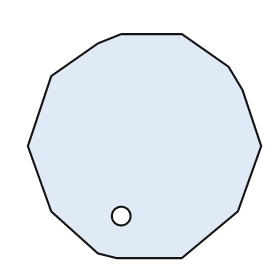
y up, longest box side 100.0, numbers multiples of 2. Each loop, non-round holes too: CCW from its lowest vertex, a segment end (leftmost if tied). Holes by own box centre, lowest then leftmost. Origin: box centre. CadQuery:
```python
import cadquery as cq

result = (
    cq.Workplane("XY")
    .moveTo(-12.0, -48.0)
    .lineTo(16.0, -48.0)
    .lineTo(40.0, -28.0)
    .lineTo(50.0, 0.0)
    .lineTo(42.0, 24.0)
    .lineTo(36.0, 34.0)
    .lineTo(16.0, 48.0)
    .lineTo(-10.0, 48.0)
    .lineTo(-20.0, 44.0)
    .lineTo(-40.0, 30.0)
    .lineTo(-50.0, 0.0)
    .lineTo(-40.0, -28.0)
    .lineTo(-20.0, -46.0)
    .close()
    .moveTo(-10.0, -30.0)
    .circle(4.0)
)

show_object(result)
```